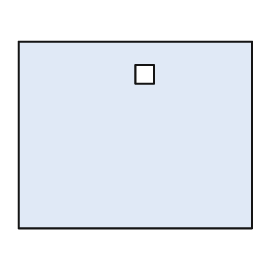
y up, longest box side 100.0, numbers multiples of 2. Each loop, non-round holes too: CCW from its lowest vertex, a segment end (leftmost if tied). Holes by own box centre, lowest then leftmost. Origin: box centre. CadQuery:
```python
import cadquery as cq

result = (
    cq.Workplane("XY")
    .moveTo(-50.0, -40.0)
    .lineTo(50.0, -40.0)
    .lineTo(50.0, 40.0)
    .lineTo(-50.0, 40.0)
    .close()
    .moveTo(0.0, 22.0)
    .lineTo(8.0, 22.0)
    .lineTo(8.0, 30.0)
    .lineTo(0.0, 30.0)
    .close()
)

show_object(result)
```